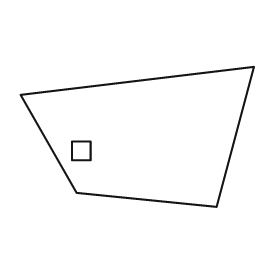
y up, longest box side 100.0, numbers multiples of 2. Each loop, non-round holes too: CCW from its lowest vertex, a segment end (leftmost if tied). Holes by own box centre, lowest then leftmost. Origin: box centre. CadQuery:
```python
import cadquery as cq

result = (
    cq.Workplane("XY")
    .moveTo(34.0, -30.0)
    .lineTo(50.0, 30.0)
    .lineTo(-50.0, 18.0)
    .lineTo(-26.0, -24.0)
    .close()
    .moveTo(-28.0, -10.0)
    .lineTo(-20.0, -10.0)
    .lineTo(-20.0, -2.0)
    .lineTo(-28.0, -2.0)
    .close()
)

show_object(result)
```